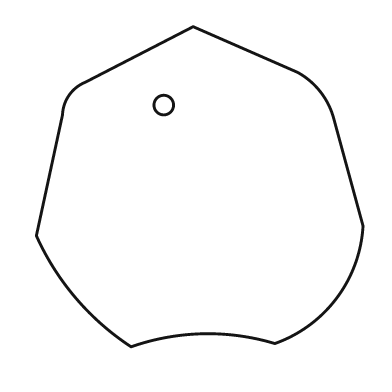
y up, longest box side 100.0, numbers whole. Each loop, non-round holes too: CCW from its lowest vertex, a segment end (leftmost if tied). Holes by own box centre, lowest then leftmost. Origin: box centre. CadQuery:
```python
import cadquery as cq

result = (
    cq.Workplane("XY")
    .moveTo(-21.0, -49.0)
    .threePointArc((1.0, -45.0), (23.0, -48.0))
    .threePointArc((42.0, -34.0), (50.0, -12.0))
    .lineTo(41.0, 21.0)
    .threePointArc((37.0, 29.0), (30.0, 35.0))
    .lineTo(-2.0, 49.0)
    .lineTo(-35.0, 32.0)
    .threePointArc((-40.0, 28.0), (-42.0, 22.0))
    .lineTo(-50.0, -15.0)
    .threePointArc((-38.0, -34.0), (-21.0, -49.0))
    .close()
    .moveTo(-11.0, 25.0)
    .circle(3.0)
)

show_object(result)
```